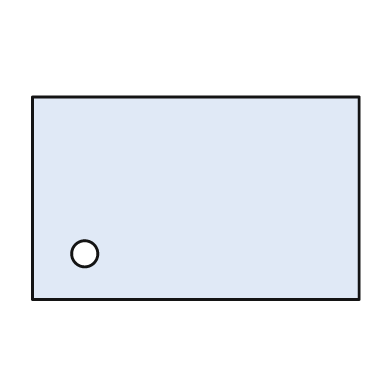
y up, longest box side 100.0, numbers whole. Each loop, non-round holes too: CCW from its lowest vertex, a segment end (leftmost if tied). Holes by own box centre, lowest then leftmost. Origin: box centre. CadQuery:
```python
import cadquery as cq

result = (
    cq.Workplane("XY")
    .moveTo(-50.0, -31.0)
    .lineTo(50.0, -31.0)
    .lineTo(50.0, 31.0)
    .lineTo(-50.0, 31.0)
    .close()
    .moveTo(-34.0, -17.0)
    .circle(4.0)
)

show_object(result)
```